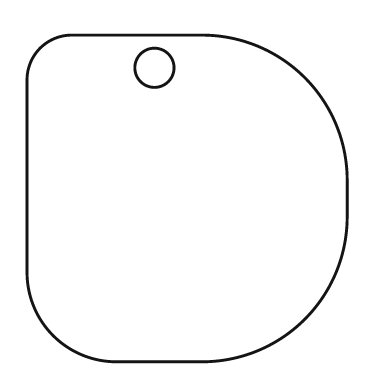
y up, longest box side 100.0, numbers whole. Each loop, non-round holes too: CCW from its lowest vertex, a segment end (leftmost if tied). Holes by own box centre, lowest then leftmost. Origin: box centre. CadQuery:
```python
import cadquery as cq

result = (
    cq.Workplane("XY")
    .moveTo(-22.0, -50.0)
    .lineTo(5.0, -50.0)
    .threePointArc((36.0, -37.0), (49.0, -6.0))
    .lineTo(49.0, 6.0)
    .threePointArc((36.0, 37.0), (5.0, 50.0))
    .lineTo(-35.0, 50.0)
    .threePointArc((-45.0, 46.0), (-49.0, 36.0))
    .lineTo(-49.0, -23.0)
    .threePointArc((-41.0, -42.0), (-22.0, -50.0))
    .close()
    .moveTo(-10.0, 40.0)
    .circle(6.0)
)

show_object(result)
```